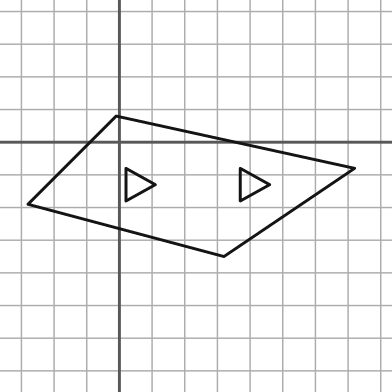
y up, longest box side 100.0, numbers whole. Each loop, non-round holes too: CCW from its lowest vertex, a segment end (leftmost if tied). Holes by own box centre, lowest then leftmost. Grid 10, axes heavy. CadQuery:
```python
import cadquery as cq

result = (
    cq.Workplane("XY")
    .moveTo(32.0, -35.0)
    .lineTo(72.0, -8.0)
    .lineTo(-1.0, 8.0)
    .lineTo(-28.0, -19.0)
    .close()
    .moveTo(2.0, -18.0)
    .lineTo(11.0, -13.0)
    .lineTo(2.0, -8.0)
    .close()
    .moveTo(37.0, -18.0)
    .lineTo(46.0, -13.0)
    .lineTo(37.0, -8.0)
    .close()
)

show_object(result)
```